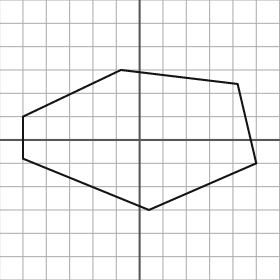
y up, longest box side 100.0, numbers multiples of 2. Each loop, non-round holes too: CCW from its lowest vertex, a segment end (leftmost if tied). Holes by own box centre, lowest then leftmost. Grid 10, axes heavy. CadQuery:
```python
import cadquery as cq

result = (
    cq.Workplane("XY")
    .moveTo(4.0, -30.0)
    .lineTo(50.0, -10.0)
    .lineTo(42.0, 24.0)
    .lineTo(-8.0, 30.0)
    .lineTo(-50.0, 10.0)
    .lineTo(-50.0, -8.0)
    .close()
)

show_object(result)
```